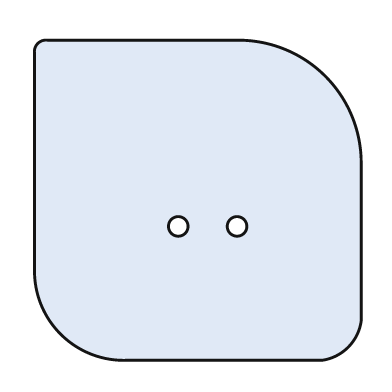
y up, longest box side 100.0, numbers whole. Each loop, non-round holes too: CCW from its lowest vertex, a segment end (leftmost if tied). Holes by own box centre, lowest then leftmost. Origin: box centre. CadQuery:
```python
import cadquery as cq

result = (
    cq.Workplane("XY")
    .moveTo(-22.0, -49.0)
    .lineTo(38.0, -49.0)
    .threePointArc((46.0, -45.0), (50.0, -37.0))
    .lineTo(50.0, 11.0)
    .threePointArc((39.0, 38.0), (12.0, 49.0))
    .lineTo(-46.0, 49.0)
    .threePointArc((-49.0, 48.0), (-50.0, 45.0))
    .lineTo(-50.0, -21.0)
    .threePointArc((-42.0, -41.0), (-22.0, -49.0))
    .close()
    .moveTo(-6.0, -8.0)
    .circle(3.0)
    .moveTo(12.0, -8.0)
    .circle(3.0)
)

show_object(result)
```